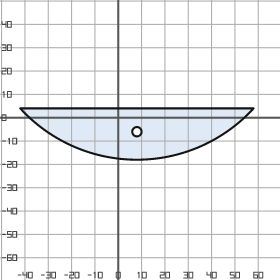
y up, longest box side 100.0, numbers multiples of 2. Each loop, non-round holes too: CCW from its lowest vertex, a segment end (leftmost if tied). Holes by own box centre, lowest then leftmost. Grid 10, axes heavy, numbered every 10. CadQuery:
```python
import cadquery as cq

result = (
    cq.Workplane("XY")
    .moveTo(-42.0, 4.0)
    .threePointArc((8.0, -18.0), (58.0, 4.0))
    .close()
    .moveTo(8.0, -6.0)
    .circle(2.0)
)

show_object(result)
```